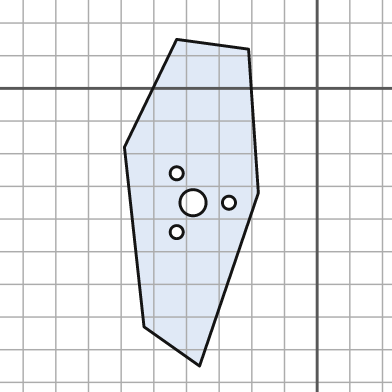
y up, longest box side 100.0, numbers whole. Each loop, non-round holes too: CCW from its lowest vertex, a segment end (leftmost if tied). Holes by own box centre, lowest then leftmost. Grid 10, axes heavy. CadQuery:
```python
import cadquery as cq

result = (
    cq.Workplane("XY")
    .moveTo(-36.0, -85.0)
    .lineTo(-18.0, -32.0)
    .lineTo(-21.0, 12.0)
    .lineTo(-43.0, 15.0)
    .lineTo(-59.0, -18.0)
    .lineTo(-53.0, -73.0)
    .close()
    .moveTo(-43.0, -44.0)
    .circle(2.0)
    .moveTo(-38.0, -35.0)
    .circle(4.0)
    .moveTo(-27.0, -35.0)
    .circle(2.0)
    .moveTo(-43.0, -26.0)
    .circle(2.0)
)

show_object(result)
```